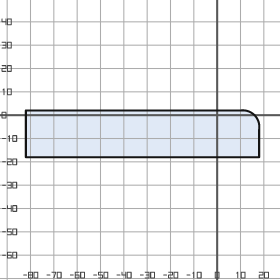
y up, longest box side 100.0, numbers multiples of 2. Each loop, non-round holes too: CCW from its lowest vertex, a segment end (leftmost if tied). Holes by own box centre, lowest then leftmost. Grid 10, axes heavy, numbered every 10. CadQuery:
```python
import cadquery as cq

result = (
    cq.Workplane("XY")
    .moveTo(-82.0, -18.0)
    .lineTo(18.0, -18.0)
    .lineTo(18.0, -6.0)
    .threePointArc((16.0, 0.0), (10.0, 2.0))
    .lineTo(-82.0, 2.0)
    .close()
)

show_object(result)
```